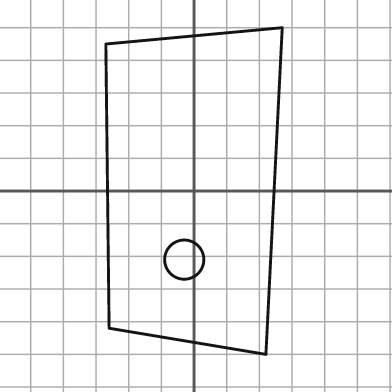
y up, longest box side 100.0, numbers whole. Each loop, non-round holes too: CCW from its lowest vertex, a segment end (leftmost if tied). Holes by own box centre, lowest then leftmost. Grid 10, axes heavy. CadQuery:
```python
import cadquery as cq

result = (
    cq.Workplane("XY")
    .moveTo(22.0, -50.0)
    .lineTo(27.0, 50.0)
    .lineTo(-27.0, 45.0)
    .lineTo(-26.0, -42.0)
    .close()
    .moveTo(-3.0, -21.0)
    .circle(6.0)
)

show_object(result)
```